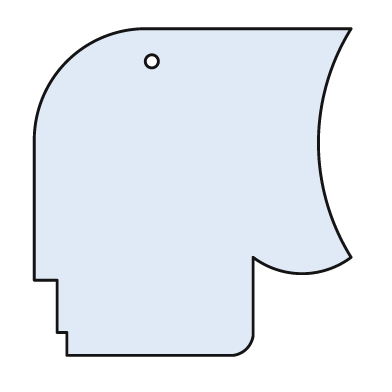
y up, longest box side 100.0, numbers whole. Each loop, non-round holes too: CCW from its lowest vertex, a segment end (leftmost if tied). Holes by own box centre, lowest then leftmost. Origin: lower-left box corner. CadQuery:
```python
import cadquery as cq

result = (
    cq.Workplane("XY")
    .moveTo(10.0, 0.0)
    .lineTo(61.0, 0.0)
    .threePointArc((65.0, 2.0), (67.0, 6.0))
    .lineTo(67.0, 30.0)
    .threePointArc((82.0, 25.0), (97.0, 30.0))
    .threePointArc((87.0, 65.0), (97.0, 100.0))
    .lineTo(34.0, 100.0)
    .threePointArc((10.0, 90.0), (0.0, 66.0))
    .lineTo(0.0, 23.0)
    .lineTo(7.0, 23.0)
    .lineTo(7.0, 7.0)
    .lineTo(10.0, 7.0)
    .close()
    .moveTo(36.0, 90.0)
    .circle(2.0)
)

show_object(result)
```